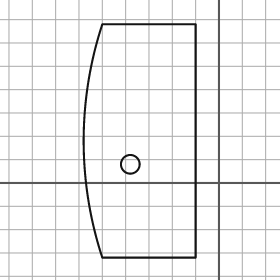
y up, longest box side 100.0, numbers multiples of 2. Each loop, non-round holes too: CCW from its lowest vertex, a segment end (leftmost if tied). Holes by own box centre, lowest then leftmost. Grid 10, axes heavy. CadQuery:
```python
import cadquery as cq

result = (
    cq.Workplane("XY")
    .moveTo(-50.0, -32.0)
    .lineTo(-10.0, -32.0)
    .lineTo(-10.0, 68.0)
    .lineTo(-50.0, 68.0)
    .threePointArc((-58.0, 18.0), (-50.0, -32.0))
    .close()
    .moveTo(-38.0, 8.0)
    .circle(4.0)
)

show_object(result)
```